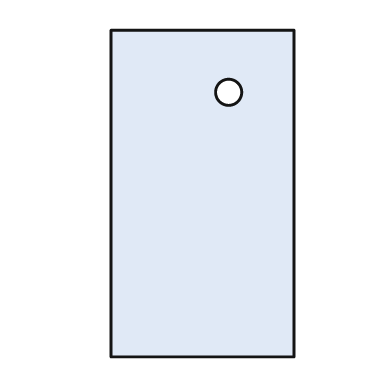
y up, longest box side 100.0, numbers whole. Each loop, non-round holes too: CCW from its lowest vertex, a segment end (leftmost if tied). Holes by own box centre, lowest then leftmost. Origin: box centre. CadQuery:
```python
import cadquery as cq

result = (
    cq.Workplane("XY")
    .moveTo(-28.0, -50.0)
    .lineTo(28.0, -50.0)
    .lineTo(28.0, 50.0)
    .lineTo(-28.0, 50.0)
    .close()
    .moveTo(8.0, 31.0)
    .circle(4.0)
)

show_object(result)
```